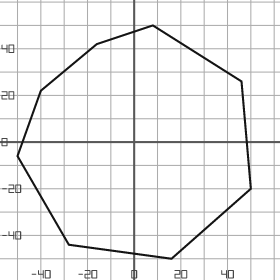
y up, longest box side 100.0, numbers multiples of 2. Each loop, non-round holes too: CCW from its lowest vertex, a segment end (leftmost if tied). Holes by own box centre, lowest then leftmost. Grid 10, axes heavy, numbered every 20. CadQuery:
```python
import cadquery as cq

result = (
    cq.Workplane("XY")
    .moveTo(16.0, -50.0)
    .lineTo(50.0, -20.0)
    .lineTo(46.0, 26.0)
    .lineTo(8.0, 50.0)
    .lineTo(-16.0, 42.0)
    .lineTo(-40.0, 22.0)
    .lineTo(-50.0, -6.0)
    .lineTo(-28.0, -44.0)
    .close()
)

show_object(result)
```